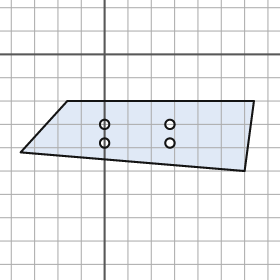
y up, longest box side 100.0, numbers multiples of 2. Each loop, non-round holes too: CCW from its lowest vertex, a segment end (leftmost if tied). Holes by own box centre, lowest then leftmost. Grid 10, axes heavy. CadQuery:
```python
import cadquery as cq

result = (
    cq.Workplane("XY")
    .moveTo(60.0, -50.0)
    .lineTo(64.0, -20.0)
    .lineTo(-16.0, -20.0)
    .lineTo(-36.0, -42.0)
    .close()
    .moveTo(0.0, -38.0)
    .circle(2.0)
    .moveTo(28.0, -38.0)
    .circle(2.0)
    .moveTo(0.0, -30.0)
    .circle(2.0)
    .moveTo(28.0, -30.0)
    .circle(2.0)
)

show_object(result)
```